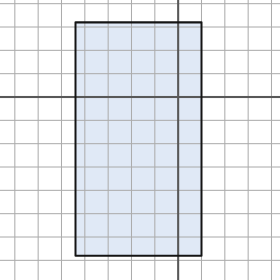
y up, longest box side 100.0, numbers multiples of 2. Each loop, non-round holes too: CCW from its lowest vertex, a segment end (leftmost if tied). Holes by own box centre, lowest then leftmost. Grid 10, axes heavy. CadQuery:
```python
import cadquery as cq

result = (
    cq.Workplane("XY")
    .moveTo(-44.0, -68.0)
    .lineTo(10.0, -68.0)
    .lineTo(10.0, 32.0)
    .lineTo(-44.0, 32.0)
    .close()
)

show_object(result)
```